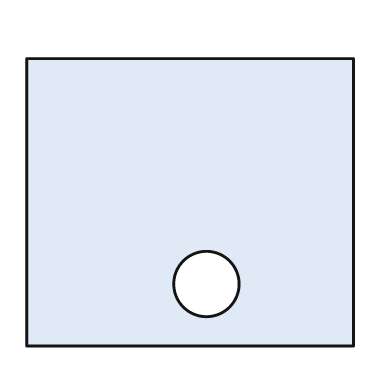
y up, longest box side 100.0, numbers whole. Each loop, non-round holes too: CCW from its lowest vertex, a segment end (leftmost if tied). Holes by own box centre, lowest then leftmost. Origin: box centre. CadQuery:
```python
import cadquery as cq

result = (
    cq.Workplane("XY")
    .moveTo(-50.0, -44.0)
    .lineTo(50.0, -44.0)
    .lineTo(50.0, 44.0)
    .lineTo(-50.0, 44.0)
    .close()
    .moveTo(5.0, -25.0)
    .circle(10.0)
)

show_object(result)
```